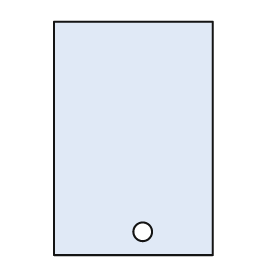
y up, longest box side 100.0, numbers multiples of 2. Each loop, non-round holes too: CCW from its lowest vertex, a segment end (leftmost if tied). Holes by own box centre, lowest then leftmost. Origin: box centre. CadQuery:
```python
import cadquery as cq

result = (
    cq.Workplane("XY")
    .moveTo(-34.0, -50.0)
    .lineTo(34.0, -50.0)
    .lineTo(34.0, 50.0)
    .lineTo(-34.0, 50.0)
    .close()
    .moveTo(4.0, -40.0)
    .circle(4.0)
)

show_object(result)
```